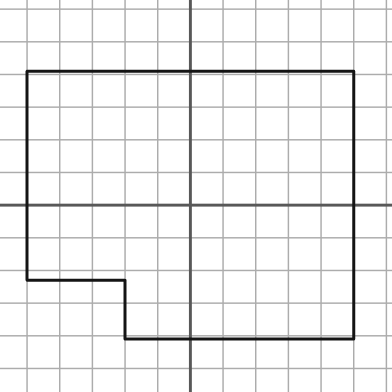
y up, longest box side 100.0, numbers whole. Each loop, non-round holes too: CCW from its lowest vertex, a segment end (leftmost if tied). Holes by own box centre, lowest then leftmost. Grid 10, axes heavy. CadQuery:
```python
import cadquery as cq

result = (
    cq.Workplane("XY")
    .moveTo(-20.0, -41.0)
    .lineTo(50.0, -41.0)
    .lineTo(50.0, 41.0)
    .lineTo(-50.0, 41.0)
    .lineTo(-50.0, -23.0)
    .lineTo(-20.0, -23.0)
    .close()
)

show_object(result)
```